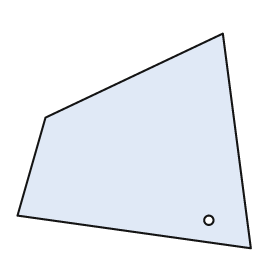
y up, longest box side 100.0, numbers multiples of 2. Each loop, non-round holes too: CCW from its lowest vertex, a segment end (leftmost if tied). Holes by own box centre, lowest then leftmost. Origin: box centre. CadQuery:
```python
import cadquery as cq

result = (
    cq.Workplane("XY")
    .moveTo(50.0, -46.0)
    .lineTo(38.0, 46.0)
    .lineTo(-38.0, 10.0)
    .lineTo(-50.0, -32.0)
    .close()
    .moveTo(32.0, -34.0)
    .circle(2.0)
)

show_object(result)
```